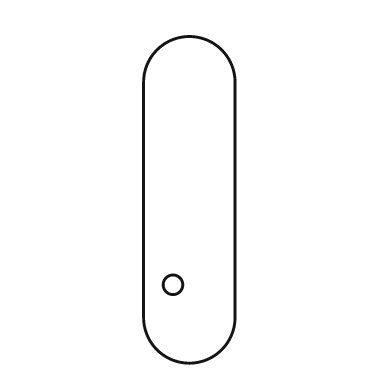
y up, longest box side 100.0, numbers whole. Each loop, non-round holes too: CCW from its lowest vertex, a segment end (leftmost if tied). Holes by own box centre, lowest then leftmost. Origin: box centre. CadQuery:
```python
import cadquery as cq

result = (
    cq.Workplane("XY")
    .moveTo(-14.0, -36.0)
    .threePointArc((0.0, -50.0), (14.0, -36.0))
    .lineTo(14.0, 36.0)
    .threePointArc((0.0, 50.0), (-14.0, 36.0))
    .close()
    .moveTo(-5.0, -26.0)
    .circle(3.0)
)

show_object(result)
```